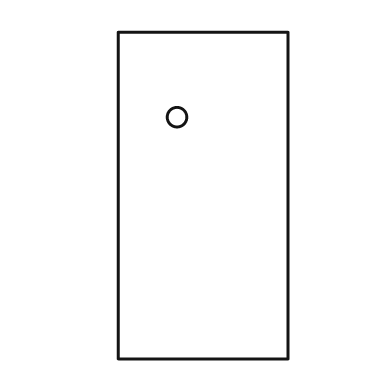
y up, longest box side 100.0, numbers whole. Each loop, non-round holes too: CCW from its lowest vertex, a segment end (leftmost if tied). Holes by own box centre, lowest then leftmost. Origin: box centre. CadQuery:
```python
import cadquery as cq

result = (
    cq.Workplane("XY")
    .moveTo(-26.0, -50.0)
    .lineTo(26.0, -50.0)
    .lineTo(26.0, 50.0)
    .lineTo(-26.0, 50.0)
    .close()
    .moveTo(-8.0, 24.0)
    .circle(3.0)
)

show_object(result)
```